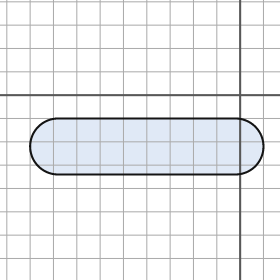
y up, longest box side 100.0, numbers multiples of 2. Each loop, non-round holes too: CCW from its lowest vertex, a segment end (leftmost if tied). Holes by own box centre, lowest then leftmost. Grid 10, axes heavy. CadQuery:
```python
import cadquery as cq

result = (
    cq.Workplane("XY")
    .moveTo(-78.0, -34.0)
    .lineTo(-2.0, -34.0)
    .threePointArc((10.0, -22.0), (-2.0, -10.0))
    .lineTo(-78.0, -10.0)
    .threePointArc((-90.0, -22.0), (-78.0, -34.0))
    .close()
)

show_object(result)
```